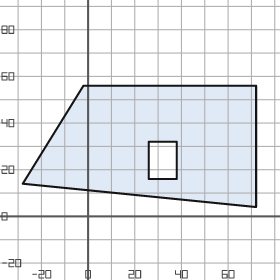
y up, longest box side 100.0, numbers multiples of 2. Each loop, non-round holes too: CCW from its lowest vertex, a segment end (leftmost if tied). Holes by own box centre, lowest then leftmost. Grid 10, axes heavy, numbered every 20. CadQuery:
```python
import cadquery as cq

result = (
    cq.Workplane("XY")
    .moveTo(72.0, 4.0)
    .lineTo(72.0, 56.0)
    .lineTo(-2.0, 56.0)
    .lineTo(-28.0, 14.0)
    .close()
    .moveTo(26.0, 16.0)
    .lineTo(38.0, 16.0)
    .lineTo(38.0, 32.0)
    .lineTo(26.0, 32.0)
    .close()
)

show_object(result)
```